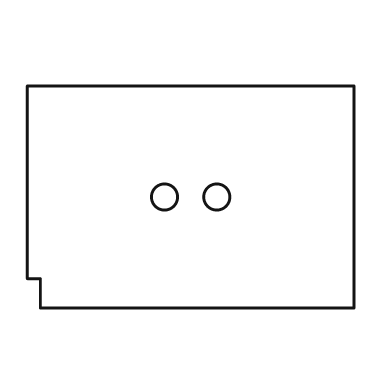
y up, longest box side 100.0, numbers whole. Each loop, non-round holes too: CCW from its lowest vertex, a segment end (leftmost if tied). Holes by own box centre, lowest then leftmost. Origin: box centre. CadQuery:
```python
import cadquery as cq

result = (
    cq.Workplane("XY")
    .moveTo(-46.0, -34.0)
    .lineTo(50.0, -34.0)
    .lineTo(50.0, 34.0)
    .lineTo(-50.0, 34.0)
    .lineTo(-50.0, -25.0)
    .lineTo(-46.0, -25.0)
    .close()
    .moveTo(-8.0, 0.0)
    .circle(4.0)
    .moveTo(8.0, 0.0)
    .circle(4.0)
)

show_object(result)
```